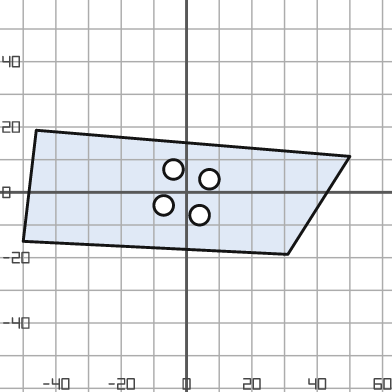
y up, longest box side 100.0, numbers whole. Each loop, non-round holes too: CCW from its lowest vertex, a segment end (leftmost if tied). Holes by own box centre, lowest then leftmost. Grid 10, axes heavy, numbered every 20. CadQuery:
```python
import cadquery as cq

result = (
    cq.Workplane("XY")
    .moveTo(31.0, -19.0)
    .lineTo(50.0, 11.0)
    .lineTo(-46.0, 19.0)
    .lineTo(-50.0, -15.0)
    .close()
    .moveTo(4.0, -7.0)
    .circle(3.0)
    .moveTo(-7.0, -4.0)
    .circle(3.0)
    .moveTo(7.0, 4.0)
    .circle(3.0)
    .moveTo(-4.0, 7.0)
    .circle(3.0)
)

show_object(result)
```